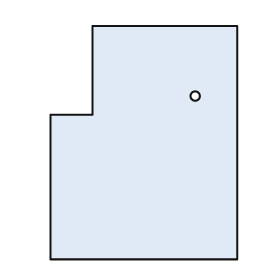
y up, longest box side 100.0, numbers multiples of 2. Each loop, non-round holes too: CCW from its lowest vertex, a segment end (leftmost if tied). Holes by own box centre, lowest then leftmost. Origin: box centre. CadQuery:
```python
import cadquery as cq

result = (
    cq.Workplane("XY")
    .moveTo(-40.0, -50.0)
    .lineTo(40.0, -50.0)
    .lineTo(40.0, 50.0)
    .lineTo(-22.0, 50.0)
    .lineTo(-22.0, 12.0)
    .lineTo(-40.0, 12.0)
    .close()
    .moveTo(22.0, 20.0)
    .circle(2.0)
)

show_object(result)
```